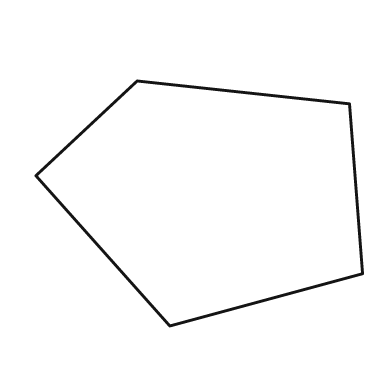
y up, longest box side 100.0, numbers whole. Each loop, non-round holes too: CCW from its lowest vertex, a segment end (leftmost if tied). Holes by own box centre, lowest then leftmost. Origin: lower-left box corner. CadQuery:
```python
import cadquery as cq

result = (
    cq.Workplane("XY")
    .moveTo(41.0, 0.0)
    .lineTo(100.0, 16.0)
    .lineTo(96.0, 68.0)
    .lineTo(31.0, 75.0)
    .lineTo(0.0, 46.0)
    .close()
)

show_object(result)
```